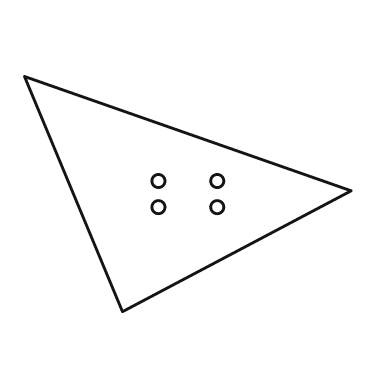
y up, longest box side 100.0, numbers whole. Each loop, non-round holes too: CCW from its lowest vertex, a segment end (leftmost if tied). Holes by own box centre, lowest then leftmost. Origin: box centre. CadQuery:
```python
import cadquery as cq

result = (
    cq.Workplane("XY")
    .moveTo(-20.0, -36.0)
    .lineTo(50.0, 1.0)
    .lineTo(-50.0, 36.0)
    .close()
    .moveTo(-9.0, -4.0)
    .circle(2.0)
    .moveTo(9.0, -4.0)
    .circle(2.0)
    .moveTo(-9.0, 4.0)
    .circle(2.0)
    .moveTo(9.0, 4.0)
    .circle(2.0)
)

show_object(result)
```